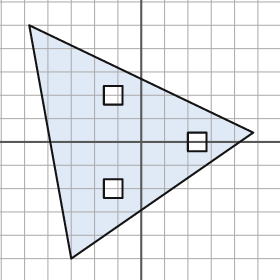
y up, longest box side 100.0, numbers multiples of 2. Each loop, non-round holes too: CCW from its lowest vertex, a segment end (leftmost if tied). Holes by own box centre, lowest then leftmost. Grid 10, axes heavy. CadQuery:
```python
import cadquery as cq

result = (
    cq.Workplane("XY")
    .moveTo(-30.0, -50.0)
    .lineTo(48.0, 4.0)
    .lineTo(-48.0, 50.0)
    .close()
    .moveTo(-16.0, -24.0)
    .lineTo(-8.0, -24.0)
    .lineTo(-8.0, -16.0)
    .lineTo(-16.0, -16.0)
    .close()
    .moveTo(20.0, -4.0)
    .lineTo(28.0, -4.0)
    .lineTo(28.0, 4.0)
    .lineTo(20.0, 4.0)
    .close()
    .moveTo(-16.0, 16.0)
    .lineTo(-8.0, 16.0)
    .lineTo(-8.0, 24.0)
    .lineTo(-16.0, 24.0)
    .close()
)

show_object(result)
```